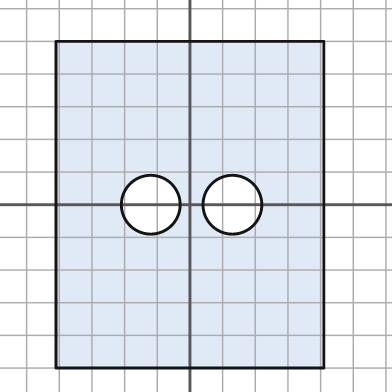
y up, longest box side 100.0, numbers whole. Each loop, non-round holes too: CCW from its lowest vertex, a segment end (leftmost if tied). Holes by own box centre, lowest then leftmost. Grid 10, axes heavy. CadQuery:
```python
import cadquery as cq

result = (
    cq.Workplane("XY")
    .moveTo(-41.0, -50.0)
    .lineTo(41.0, -50.0)
    .lineTo(41.0, 50.0)
    .lineTo(-41.0, 50.0)
    .close()
    .moveTo(-12.0, 0.0)
    .circle(9.0)
    .moveTo(13.0, 0.0)
    .circle(9.0)
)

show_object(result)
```